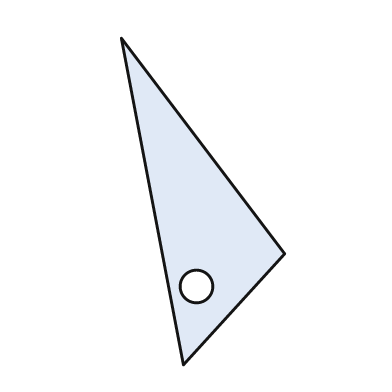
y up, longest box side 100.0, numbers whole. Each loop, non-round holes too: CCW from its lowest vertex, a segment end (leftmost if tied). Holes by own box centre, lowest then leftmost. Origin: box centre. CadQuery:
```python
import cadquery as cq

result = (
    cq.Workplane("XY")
    .moveTo(-6.0, -50.0)
    .lineTo(25.0, -16.0)
    .lineTo(-25.0, 50.0)
    .close()
    .moveTo(-2.0, -26.0)
    .circle(5.0)
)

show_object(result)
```